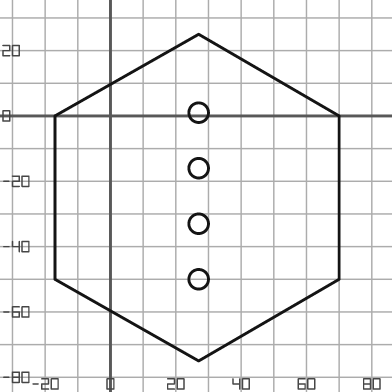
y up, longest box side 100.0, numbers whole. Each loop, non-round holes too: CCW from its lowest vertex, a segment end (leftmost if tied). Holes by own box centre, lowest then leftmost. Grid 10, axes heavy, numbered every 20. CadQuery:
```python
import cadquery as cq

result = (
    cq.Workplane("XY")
    .moveTo(27.0, -75.0)
    .lineTo(70.0, -50.0)
    .lineTo(70.0, 0.0)
    .lineTo(27.0, 25.0)
    .lineTo(-17.0, 0.0)
    .lineTo(-17.0, -50.0)
    .close()
    .moveTo(27.0, -50.0)
    .circle(3.0)
    .moveTo(27.0, -33.0)
    .circle(3.0)
    .moveTo(27.0, -16.0)
    .circle(3.0)
    .moveTo(27.0, 1.0)
    .circle(3.0)
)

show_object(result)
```